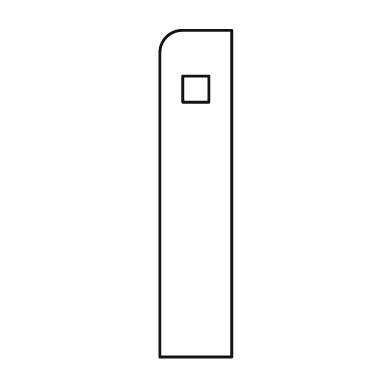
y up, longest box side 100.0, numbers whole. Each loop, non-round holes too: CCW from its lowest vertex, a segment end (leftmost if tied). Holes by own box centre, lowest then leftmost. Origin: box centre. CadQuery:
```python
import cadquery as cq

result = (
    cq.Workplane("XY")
    .moveTo(-11.0, -50.0)
    .lineTo(11.0, -50.0)
    .lineTo(11.0, 50.0)
    .lineTo(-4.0, 50.0)
    .threePointArc((-9.0, 48.0), (-11.0, 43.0))
    .close()
    .moveTo(-4.0, 28.0)
    .lineTo(4.0, 28.0)
    .lineTo(4.0, 36.0)
    .lineTo(-4.0, 36.0)
    .close()
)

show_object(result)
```